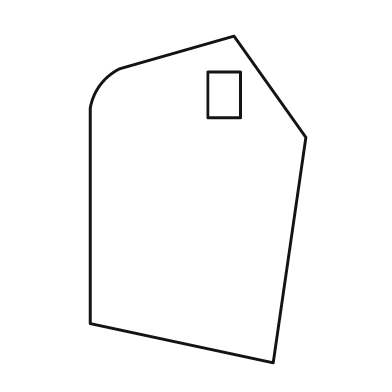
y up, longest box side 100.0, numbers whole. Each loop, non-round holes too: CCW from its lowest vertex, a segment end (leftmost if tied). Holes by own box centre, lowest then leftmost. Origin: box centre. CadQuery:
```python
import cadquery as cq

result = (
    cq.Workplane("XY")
    .moveTo(23.0, -50.0)
    .lineTo(33.0, 19.0)
    .lineTo(11.0, 50.0)
    .lineTo(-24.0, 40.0)
    .threePointArc((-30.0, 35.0), (-33.0, 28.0))
    .lineTo(-33.0, -38.0)
    .close()
    .moveTo(3.0, 25.0)
    .lineTo(13.0, 25.0)
    .lineTo(13.0, 39.0)
    .lineTo(3.0, 39.0)
    .close()
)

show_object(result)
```